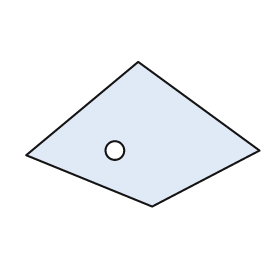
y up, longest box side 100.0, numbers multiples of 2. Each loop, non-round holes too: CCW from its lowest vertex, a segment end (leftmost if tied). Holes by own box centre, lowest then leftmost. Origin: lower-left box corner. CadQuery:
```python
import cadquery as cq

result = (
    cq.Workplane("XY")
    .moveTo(54.0, 0.0)
    .lineTo(100.0, 24.0)
    .lineTo(48.0, 62.0)
    .lineTo(0.0, 22.0)
    .close()
    .moveTo(38.0, 24.0)
    .circle(4.0)
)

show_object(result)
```